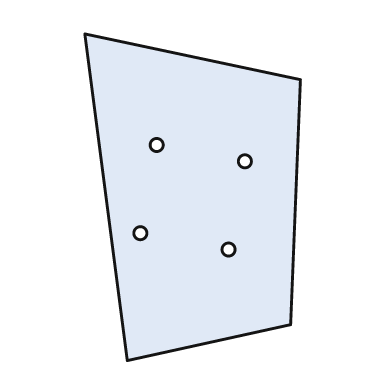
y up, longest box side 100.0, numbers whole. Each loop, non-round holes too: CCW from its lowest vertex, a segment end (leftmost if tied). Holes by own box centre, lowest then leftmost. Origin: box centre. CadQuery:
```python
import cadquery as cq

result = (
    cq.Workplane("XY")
    .moveTo(-20.0, -50.0)
    .lineTo(30.0, -39.0)
    .lineTo(33.0, 36.0)
    .lineTo(-33.0, 50.0)
    .close()
    .moveTo(11.0, -16.0)
    .circle(2.0)
    .moveTo(-16.0, -11.0)
    .circle(2.0)
    .moveTo(16.0, 11.0)
    .circle(2.0)
    .moveTo(-11.0, 16.0)
    .circle(2.0)
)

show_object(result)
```